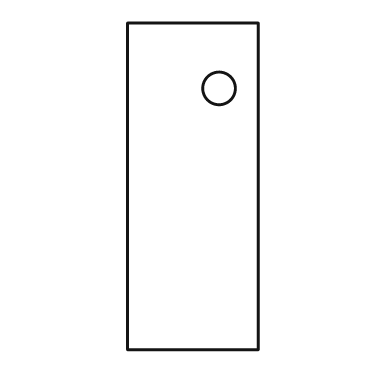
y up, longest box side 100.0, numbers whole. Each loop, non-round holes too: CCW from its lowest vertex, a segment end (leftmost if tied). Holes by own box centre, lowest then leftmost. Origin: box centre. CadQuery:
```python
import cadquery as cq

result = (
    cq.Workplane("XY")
    .moveTo(-20.0, -50.0)
    .lineTo(20.0, -50.0)
    .lineTo(20.0, 50.0)
    .lineTo(-20.0, 50.0)
    .close()
    .moveTo(8.0, 30.0)
    .circle(5.0)
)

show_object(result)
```